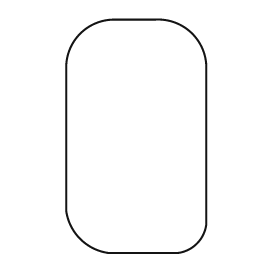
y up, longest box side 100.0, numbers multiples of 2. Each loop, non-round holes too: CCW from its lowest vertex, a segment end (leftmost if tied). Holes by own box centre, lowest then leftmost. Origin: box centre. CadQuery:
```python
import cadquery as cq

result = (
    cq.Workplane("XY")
    .moveTo(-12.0, -50.0)
    .lineTo(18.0, -50.0)
    .threePointArc((26.0, -46.0), (30.0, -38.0))
    .lineTo(30.0, 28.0)
    .threePointArc((24.0, 44.0), (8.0, 50.0))
    .lineTo(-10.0, 50.0)
    .threePointArc((-24.0, 44.0), (-30.0, 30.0))
    .lineTo(-30.0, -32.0)
    .threePointArc((-24.0, -44.0), (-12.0, -50.0))
    .close()
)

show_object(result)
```